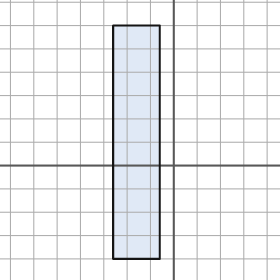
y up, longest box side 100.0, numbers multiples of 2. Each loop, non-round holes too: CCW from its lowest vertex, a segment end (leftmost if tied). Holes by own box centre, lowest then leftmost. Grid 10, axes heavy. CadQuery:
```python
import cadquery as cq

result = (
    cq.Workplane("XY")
    .moveTo(-26.0, -40.0)
    .lineTo(-6.0, -40.0)
    .lineTo(-6.0, 60.0)
    .lineTo(-26.0, 60.0)
    .close()
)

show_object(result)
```